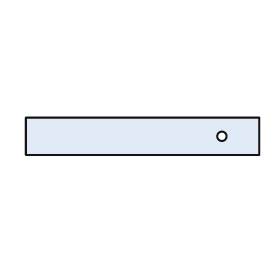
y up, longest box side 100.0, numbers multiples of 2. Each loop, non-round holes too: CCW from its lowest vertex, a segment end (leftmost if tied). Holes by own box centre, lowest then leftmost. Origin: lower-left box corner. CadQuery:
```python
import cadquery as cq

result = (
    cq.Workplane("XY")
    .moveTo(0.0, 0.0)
    .lineTo(100.0, 0.0)
    .lineTo(100.0, 16.0)
    .lineTo(0.0, 16.0)
    .close()
    .moveTo(84.0, 8.0)
    .circle(2.0)
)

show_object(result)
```